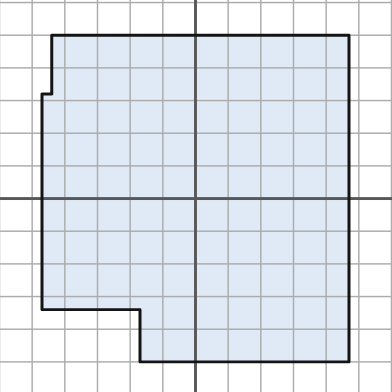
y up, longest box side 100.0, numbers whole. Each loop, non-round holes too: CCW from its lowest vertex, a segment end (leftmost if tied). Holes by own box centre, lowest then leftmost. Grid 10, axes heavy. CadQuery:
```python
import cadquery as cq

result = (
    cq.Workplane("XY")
    .moveTo(-17.0, -50.0)
    .lineTo(47.0, -50.0)
    .lineTo(47.0, 50.0)
    .lineTo(-44.0, 50.0)
    .lineTo(-44.0, 32.0)
    .lineTo(-47.0, 32.0)
    .lineTo(-47.0, -34.0)
    .lineTo(-17.0, -34.0)
    .close()
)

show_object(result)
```